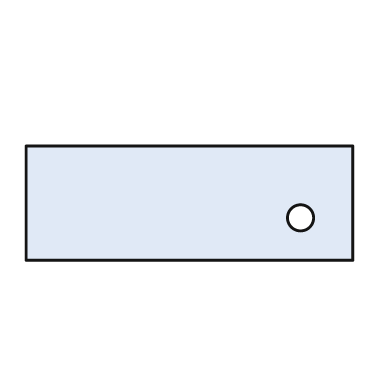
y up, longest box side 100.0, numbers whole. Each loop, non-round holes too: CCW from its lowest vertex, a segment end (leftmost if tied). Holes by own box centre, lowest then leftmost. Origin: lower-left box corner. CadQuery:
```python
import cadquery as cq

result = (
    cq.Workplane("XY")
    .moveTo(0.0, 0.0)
    .lineTo(100.0, 0.0)
    .lineTo(100.0, 35.0)
    .lineTo(0.0, 35.0)
    .close()
    .moveTo(84.0, 13.0)
    .circle(4.0)
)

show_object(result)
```